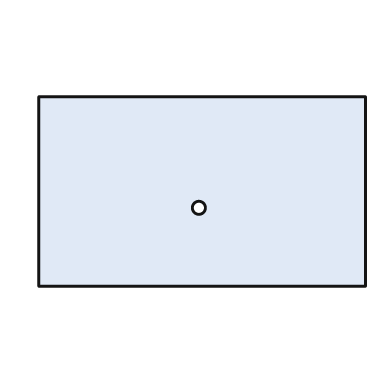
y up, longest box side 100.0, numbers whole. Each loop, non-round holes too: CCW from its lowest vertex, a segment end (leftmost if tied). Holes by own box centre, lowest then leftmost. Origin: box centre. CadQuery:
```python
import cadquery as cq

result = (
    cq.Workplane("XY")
    .moveTo(-50.0, -29.0)
    .lineTo(50.0, -29.0)
    .lineTo(50.0, 29.0)
    .lineTo(-50.0, 29.0)
    .close()
    .moveTo(-1.0, -5.0)
    .circle(2.0)
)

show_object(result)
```